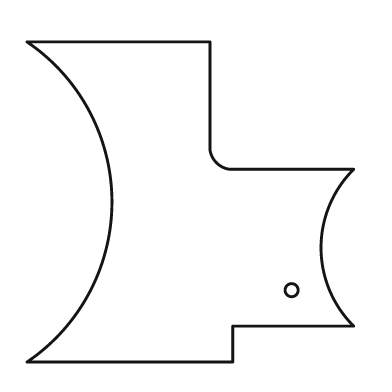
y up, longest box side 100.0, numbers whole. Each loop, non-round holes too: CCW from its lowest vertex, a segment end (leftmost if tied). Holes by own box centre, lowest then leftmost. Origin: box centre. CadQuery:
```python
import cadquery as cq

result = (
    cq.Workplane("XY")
    .moveTo(-50.0, -49.0)
    .lineTo(13.0, -49.0)
    .lineTo(13.0, -38.0)
    .lineTo(50.0, -38.0)
    .threePointArc((40.0, -14.0), (50.0, 10.0))
    .lineTo(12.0, 10.0)
    .threePointArc((8.0, 12.0), (6.0, 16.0))
    .lineTo(6.0, 49.0)
    .lineTo(-50.0, 49.0)
    .threePointArc((-24.0, 0.0), (-50.0, -49.0))
    .close()
    .moveTo(31.0, -27.0)
    .circle(2.0)
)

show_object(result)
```